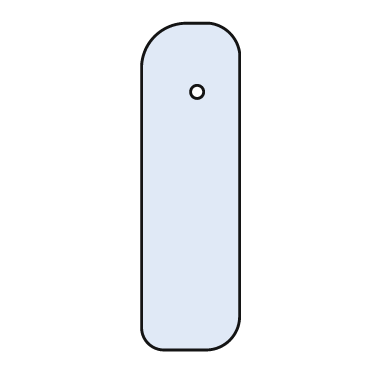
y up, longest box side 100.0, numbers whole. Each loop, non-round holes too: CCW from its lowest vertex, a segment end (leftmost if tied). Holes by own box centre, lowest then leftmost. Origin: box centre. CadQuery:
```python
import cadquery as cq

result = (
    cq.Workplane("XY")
    .moveTo(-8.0, -50.0)
    .lineTo(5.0, -50.0)
    .threePointArc((12.0, -47.0), (15.0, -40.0))
    .lineTo(15.0, 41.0)
    .threePointArc((12.0, 47.0), (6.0, 50.0))
    .lineTo(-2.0, 50.0)
    .threePointArc((-11.0, 46.0), (-15.0, 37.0))
    .lineTo(-15.0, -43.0)
    .threePointArc((-13.0, -48.0), (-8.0, -50.0))
    .close()
    .moveTo(2.0, 29.0)
    .circle(2.0)
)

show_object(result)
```